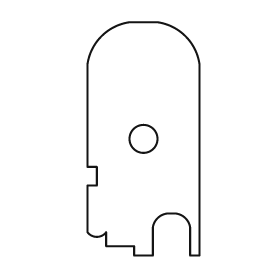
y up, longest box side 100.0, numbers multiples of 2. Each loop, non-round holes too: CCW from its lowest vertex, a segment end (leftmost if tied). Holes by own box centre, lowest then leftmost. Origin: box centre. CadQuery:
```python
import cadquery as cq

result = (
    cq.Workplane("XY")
    .moveTo(-4.0, -50.0)
    .lineTo(4.0, -50.0)
    .lineTo(4.0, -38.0)
    .threePointArc((6.0, -34.0), (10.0, -32.0))
    .lineTo(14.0, -32.0)
    .threePointArc((18.0, -34.0), (20.0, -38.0))
    .lineTo(20.0, -50.0)
    .lineTo(24.0, -50.0)
    .lineTo(24.0, 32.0)
    .threePointArc((18.0, 44.0), (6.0, 50.0))
    .lineTo(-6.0, 50.0)
    .threePointArc((-18.0, 44.0), (-24.0, 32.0))
    .lineTo(-24.0, -12.0)
    .lineTo(-20.0, -12.0)
    .lineTo(-20.0, -20.0)
    .lineTo(-24.0, -20.0)
    .lineTo(-24.0, -40.0)
    .threePointArc((-20.0, -42.0), (-16.0, -40.0))
    .lineTo(-16.0, -46.0)
    .lineTo(-4.0, -46.0)
    .close()
    .moveTo(0.0, 0.0)
    .circle(6.0)
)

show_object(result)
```